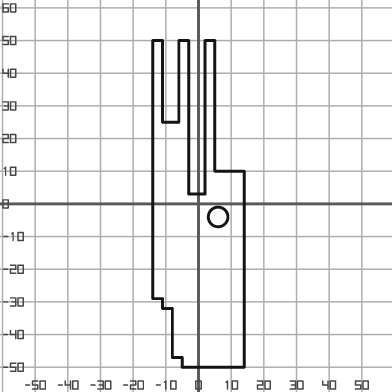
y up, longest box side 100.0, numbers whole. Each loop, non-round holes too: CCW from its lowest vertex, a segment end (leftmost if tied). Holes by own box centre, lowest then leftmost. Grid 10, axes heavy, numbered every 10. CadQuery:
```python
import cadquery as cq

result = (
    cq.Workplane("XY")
    .moveTo(-5.0, -50.0)
    .lineTo(14.0, -50.0)
    .lineTo(14.0, 10.0)
    .lineTo(5.0, 10.0)
    .lineTo(5.0, 50.0)
    .lineTo(2.0, 50.0)
    .lineTo(2.0, 3.0)
    .lineTo(-3.0, 3.0)
    .lineTo(-3.0, 50.0)
    .lineTo(-6.0, 50.0)
    .lineTo(-6.0, 25.0)
    .lineTo(-11.0, 25.0)
    .lineTo(-11.0, 50.0)
    .lineTo(-14.0, 50.0)
    .lineTo(-14.0, -29.0)
    .lineTo(-11.0, -29.0)
    .lineTo(-11.0, -32.0)
    .lineTo(-8.0, -32.0)
    .lineTo(-8.0, -47.0)
    .lineTo(-5.0, -47.0)
    .close()
    .moveTo(6.0, -4.0)
    .circle(3.0)
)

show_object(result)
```